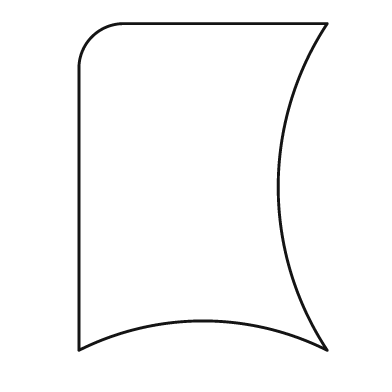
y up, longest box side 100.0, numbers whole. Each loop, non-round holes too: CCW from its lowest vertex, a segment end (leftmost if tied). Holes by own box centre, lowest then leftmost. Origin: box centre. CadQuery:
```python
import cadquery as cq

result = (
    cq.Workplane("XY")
    .moveTo(-38.0, -50.0)
    .threePointArc((0.0, -41.0), (38.0, -50.0))
    .threePointArc((23.0, 0.0), (38.0, 50.0))
    .lineTo(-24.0, 50.0)
    .threePointArc((-34.0, 46.0), (-38.0, 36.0))
    .close()
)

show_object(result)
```